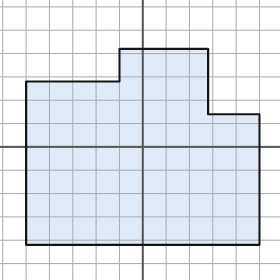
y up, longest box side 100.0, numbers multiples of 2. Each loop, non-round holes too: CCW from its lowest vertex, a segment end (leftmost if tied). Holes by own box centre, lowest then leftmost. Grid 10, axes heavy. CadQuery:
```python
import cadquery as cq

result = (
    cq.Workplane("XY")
    .moveTo(-50.0, -42.0)
    .lineTo(50.0, -42.0)
    .lineTo(50.0, 14.0)
    .lineTo(28.0, 14.0)
    .lineTo(28.0, 42.0)
    .lineTo(-10.0, 42.0)
    .lineTo(-10.0, 28.0)
    .lineTo(-50.0, 28.0)
    .close()
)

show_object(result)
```